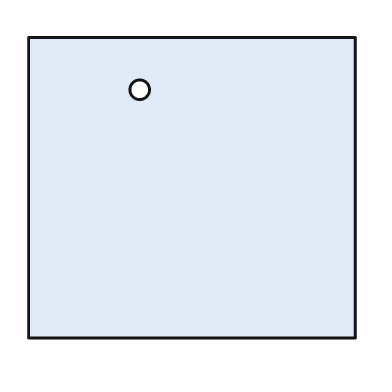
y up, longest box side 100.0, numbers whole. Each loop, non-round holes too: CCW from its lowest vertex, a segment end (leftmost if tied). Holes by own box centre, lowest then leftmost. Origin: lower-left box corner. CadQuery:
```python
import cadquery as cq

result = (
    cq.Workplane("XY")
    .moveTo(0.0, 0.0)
    .lineTo(100.0, 0.0)
    .lineTo(100.0, 92.0)
    .lineTo(0.0, 92.0)
    .close()
    .moveTo(34.0, 76.0)
    .circle(3.0)
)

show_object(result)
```